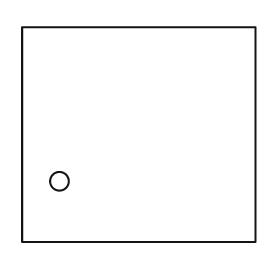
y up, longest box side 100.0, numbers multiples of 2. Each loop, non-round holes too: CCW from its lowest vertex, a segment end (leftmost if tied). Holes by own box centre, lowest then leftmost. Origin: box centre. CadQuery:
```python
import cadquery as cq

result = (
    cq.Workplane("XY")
    .moveTo(-50.0, -46.0)
    .lineTo(50.0, -46.0)
    .lineTo(50.0, 46.0)
    .lineTo(-50.0, 46.0)
    .close()
    .moveTo(-34.0, -20.0)
    .circle(4.0)
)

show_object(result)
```